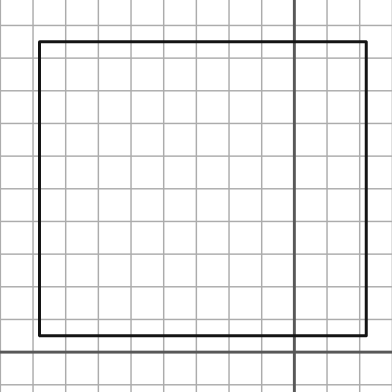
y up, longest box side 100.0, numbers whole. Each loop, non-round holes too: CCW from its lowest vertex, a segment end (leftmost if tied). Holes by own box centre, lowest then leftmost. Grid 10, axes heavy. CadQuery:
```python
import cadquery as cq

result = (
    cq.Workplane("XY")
    .moveTo(-78.0, 5.0)
    .lineTo(22.0, 5.0)
    .lineTo(22.0, 95.0)
    .lineTo(-78.0, 95.0)
    .close()
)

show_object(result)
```